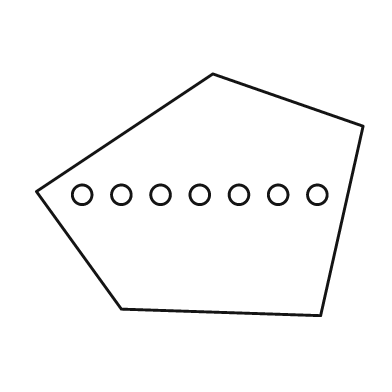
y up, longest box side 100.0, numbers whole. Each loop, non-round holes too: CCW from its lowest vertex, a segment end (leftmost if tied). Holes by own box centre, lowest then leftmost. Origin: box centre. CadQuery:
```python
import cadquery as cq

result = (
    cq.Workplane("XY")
    .moveTo(37.0, -37.0)
    .lineTo(50.0, 21.0)
    .lineTo(4.0, 37.0)
    .lineTo(-50.0, 1.0)
    .lineTo(-24.0, -35.0)
    .close()
    .moveTo(-36.0, 0.0)
    .circle(3.0)
    .moveTo(-24.0, 0.0)
    .circle(3.0)
    .moveTo(-12.0, 0.0)
    .circle(3.0)
    .moveTo(0.0, 0.0)
    .circle(3.0)
    .moveTo(12.0, 0.0)
    .circle(3.0)
    .moveTo(24.0, 0.0)
    .circle(3.0)
    .moveTo(36.0, 0.0)
    .circle(3.0)
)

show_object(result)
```